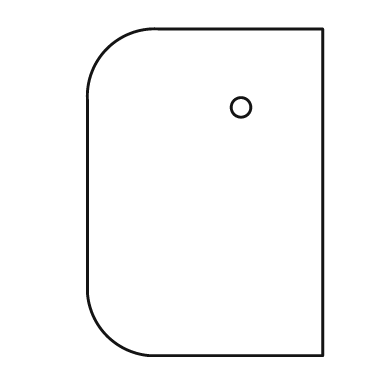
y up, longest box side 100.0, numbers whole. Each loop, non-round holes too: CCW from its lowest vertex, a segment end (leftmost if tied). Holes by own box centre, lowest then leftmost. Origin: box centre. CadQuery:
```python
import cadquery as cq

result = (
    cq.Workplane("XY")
    .moveTo(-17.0, -50.0)
    .lineTo(36.0, -50.0)
    .lineTo(36.0, 50.0)
    .lineTo(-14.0, 50.0)
    .threePointArc((-30.0, 44.0), (-36.0, 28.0))
    .lineTo(-36.0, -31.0)
    .threePointArc((-30.0, -44.0), (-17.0, -50.0))
    .close()
    .moveTo(11.0, 26.0)
    .circle(3.0)
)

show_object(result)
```